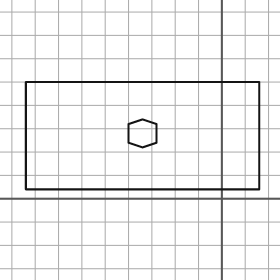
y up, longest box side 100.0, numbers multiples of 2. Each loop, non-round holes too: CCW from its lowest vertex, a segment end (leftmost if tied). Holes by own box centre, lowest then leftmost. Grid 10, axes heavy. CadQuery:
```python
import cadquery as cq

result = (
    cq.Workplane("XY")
    .moveTo(-84.0, 4.0)
    .lineTo(16.0, 4.0)
    .lineTo(16.0, 50.0)
    .lineTo(-84.0, 50.0)
    .close()
    .moveTo(-34.0, 22.0)
    .lineTo(-28.0, 24.0)
    .lineTo(-28.0, 32.0)
    .lineTo(-34.0, 34.0)
    .lineTo(-40.0, 32.0)
    .lineTo(-40.0, 24.0)
    .close()
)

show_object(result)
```